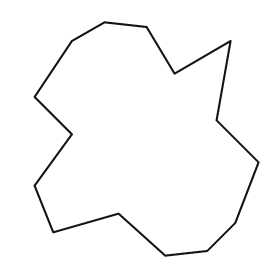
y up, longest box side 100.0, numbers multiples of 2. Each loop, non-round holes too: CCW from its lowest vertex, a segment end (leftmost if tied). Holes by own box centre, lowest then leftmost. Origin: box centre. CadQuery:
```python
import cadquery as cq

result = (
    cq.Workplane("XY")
    .moveTo(8.0, -50.0)
    .lineTo(26.0, -48.0)
    .lineTo(38.0, -36.0)
    .lineTo(48.0, -10.0)
    .lineTo(30.0, 8.0)
    .lineTo(36.0, 42.0)
    .lineTo(12.0, 28.0)
    .lineTo(0.0, 48.0)
    .lineTo(-18.0, 50.0)
    .lineTo(-32.0, 42.0)
    .lineTo(-48.0, 18.0)
    .lineTo(-32.0, 2.0)
    .lineTo(-48.0, -20.0)
    .lineTo(-40.0, -40.0)
    .lineTo(-12.0, -32.0)
    .close()
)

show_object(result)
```